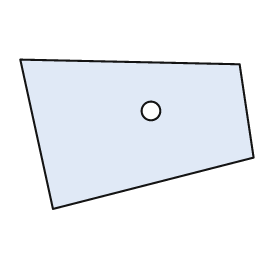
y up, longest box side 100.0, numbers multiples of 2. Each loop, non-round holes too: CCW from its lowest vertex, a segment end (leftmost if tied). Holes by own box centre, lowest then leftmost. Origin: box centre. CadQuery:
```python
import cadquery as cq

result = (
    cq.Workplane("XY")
    .moveTo(-36.0, -32.0)
    .lineTo(50.0, -10.0)
    .lineTo(44.0, 30.0)
    .lineTo(-50.0, 32.0)
    .close()
    .moveTo(6.0, 10.0)
    .circle(4.0)
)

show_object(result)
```